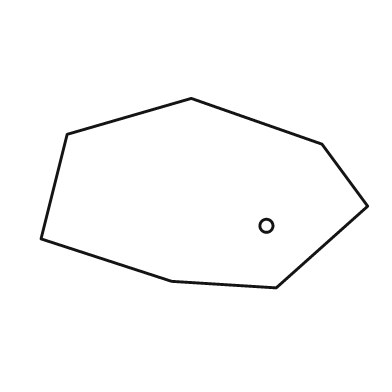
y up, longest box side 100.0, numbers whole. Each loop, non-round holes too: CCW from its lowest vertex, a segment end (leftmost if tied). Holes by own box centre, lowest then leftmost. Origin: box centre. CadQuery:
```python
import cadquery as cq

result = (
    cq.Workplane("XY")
    .moveTo(22.0, -29.0)
    .lineTo(50.0, -4.0)
    .lineTo(36.0, 15.0)
    .lineTo(-4.0, 29.0)
    .lineTo(-42.0, 18.0)
    .lineTo(-50.0, -14.0)
    .lineTo(-10.0, -27.0)
    .close()
    .moveTo(19.0, -10.0)
    .circle(2.0)
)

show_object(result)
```